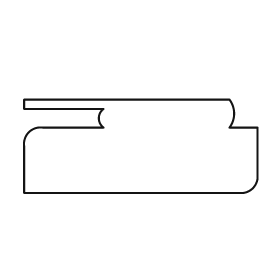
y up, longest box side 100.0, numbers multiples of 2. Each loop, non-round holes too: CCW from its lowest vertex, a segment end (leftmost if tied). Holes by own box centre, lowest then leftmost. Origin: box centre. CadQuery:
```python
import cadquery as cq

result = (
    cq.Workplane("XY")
    .moveTo(-50.0, -20.0)
    .lineTo(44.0, -20.0)
    .threePointArc((48.0, -18.0), (50.0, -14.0))
    .lineTo(50.0, 8.0)
    .lineTo(38.0, 8.0)
    .threePointArc((40.0, 14.0), (38.0, 20.0))
    .lineTo(-50.0, 20.0)
    .lineTo(-50.0, 16.0)
    .lineTo(-16.0, 16.0)
    .threePointArc((-18.0, 12.0), (-16.0, 8.0))
    .lineTo(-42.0, 8.0)
    .threePointArc((-48.0, 6.0), (-50.0, 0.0))
    .close()
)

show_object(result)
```